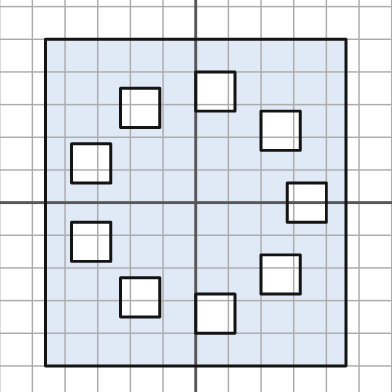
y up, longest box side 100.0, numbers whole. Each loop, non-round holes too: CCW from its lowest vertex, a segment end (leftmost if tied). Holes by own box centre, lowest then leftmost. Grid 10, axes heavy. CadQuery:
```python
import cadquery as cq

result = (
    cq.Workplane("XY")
    .moveTo(-46.0, -50.0)
    .lineTo(46.0, -50.0)
    .lineTo(46.0, 50.0)
    .lineTo(-46.0, 50.0)
    .close()
    .moveTo(0.0, -40.0)
    .lineTo(12.0, -40.0)
    .lineTo(12.0, -28.0)
    .lineTo(0.0, -28.0)
    .close()
    .moveTo(-23.0, -35.0)
    .lineTo(-11.0, -35.0)
    .lineTo(-11.0, -23.0)
    .lineTo(-23.0, -23.0)
    .close()
    .moveTo(20.0, -28.0)
    .lineTo(32.0, -28.0)
    .lineTo(32.0, -16.0)
    .lineTo(20.0, -16.0)
    .close()
    .moveTo(-38.0, -18.0)
    .lineTo(-26.0, -18.0)
    .lineTo(-26.0, -6.0)
    .lineTo(-38.0, -6.0)
    .close()
    .moveTo(28.0, -6.0)
    .lineTo(40.0, -6.0)
    .lineTo(40.0, 6.0)
    .lineTo(28.0, 6.0)
    .close()
    .moveTo(-38.0, 6.0)
    .lineTo(-26.0, 6.0)
    .lineTo(-26.0, 18.0)
    .lineTo(-38.0, 18.0)
    .close()
    .moveTo(20.0, 16.0)
    .lineTo(32.0, 16.0)
    .lineTo(32.0, 28.0)
    .lineTo(20.0, 28.0)
    .close()
    .moveTo(-23.0, 23.0)
    .lineTo(-11.0, 23.0)
    .lineTo(-11.0, 35.0)
    .lineTo(-23.0, 35.0)
    .close()
    .moveTo(0.0, 28.0)
    .lineTo(12.0, 28.0)
    .lineTo(12.0, 40.0)
    .lineTo(0.0, 40.0)
    .close()
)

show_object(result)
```